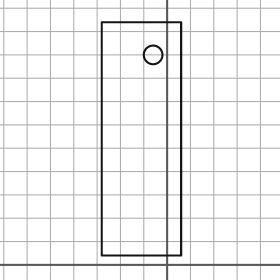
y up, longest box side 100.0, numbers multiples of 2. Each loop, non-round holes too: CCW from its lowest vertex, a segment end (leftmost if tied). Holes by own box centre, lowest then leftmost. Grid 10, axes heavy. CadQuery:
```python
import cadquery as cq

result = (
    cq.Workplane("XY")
    .moveTo(-28.0, 4.0)
    .lineTo(6.0, 4.0)
    .lineTo(6.0, 104.0)
    .lineTo(-28.0, 104.0)
    .close()
    .moveTo(-6.0, 90.0)
    .circle(4.0)
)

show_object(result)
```